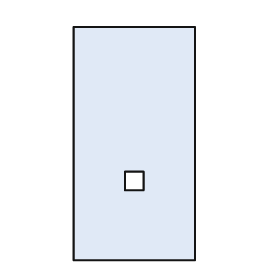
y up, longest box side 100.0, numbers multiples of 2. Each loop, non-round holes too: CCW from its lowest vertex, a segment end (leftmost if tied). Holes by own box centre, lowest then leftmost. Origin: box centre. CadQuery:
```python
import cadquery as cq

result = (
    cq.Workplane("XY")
    .moveTo(-26.0, -50.0)
    .lineTo(26.0, -50.0)
    .lineTo(26.0, 50.0)
    .lineTo(-26.0, 50.0)
    .close()
    .moveTo(-4.0, -20.0)
    .lineTo(4.0, -20.0)
    .lineTo(4.0, -12.0)
    .lineTo(-4.0, -12.0)
    .close()
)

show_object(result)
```